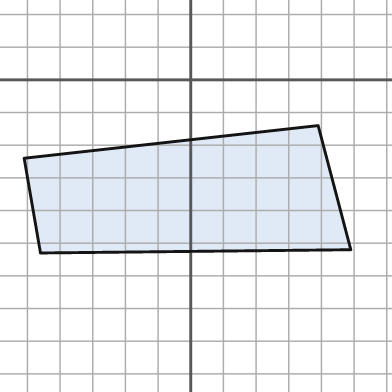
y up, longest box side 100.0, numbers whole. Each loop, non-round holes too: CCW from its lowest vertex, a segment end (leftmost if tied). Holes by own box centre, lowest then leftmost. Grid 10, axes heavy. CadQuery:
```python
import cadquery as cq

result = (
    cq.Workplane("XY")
    .moveTo(-46.0, -53.0)
    .lineTo(49.0, -52.0)
    .lineTo(39.0, -14.0)
    .lineTo(-51.0, -24.0)
    .close()
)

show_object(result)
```